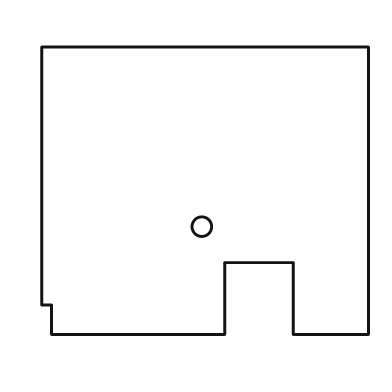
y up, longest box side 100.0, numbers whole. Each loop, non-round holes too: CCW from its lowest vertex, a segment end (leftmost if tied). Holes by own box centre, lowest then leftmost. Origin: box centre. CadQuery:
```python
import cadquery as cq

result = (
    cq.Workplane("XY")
    .moveTo(-47.0, -44.0)
    .lineTo(6.0, -44.0)
    .lineTo(6.0, -22.0)
    .lineTo(27.0, -22.0)
    .lineTo(27.0, -44.0)
    .lineTo(50.0, -44.0)
    .lineTo(50.0, 44.0)
    .lineTo(-50.0, 44.0)
    .lineTo(-50.0, -35.0)
    .lineTo(-47.0, -35.0)
    .close()
    .moveTo(-1.0, -11.0)
    .circle(3.0)
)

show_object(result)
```